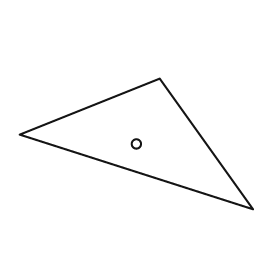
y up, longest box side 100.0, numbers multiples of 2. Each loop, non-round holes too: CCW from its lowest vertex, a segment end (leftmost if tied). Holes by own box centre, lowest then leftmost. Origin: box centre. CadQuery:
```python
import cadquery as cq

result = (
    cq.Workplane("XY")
    .moveTo(50.0, -28.0)
    .lineTo(10.0, 28.0)
    .lineTo(-50.0, 4.0)
    .close()
    .moveTo(0.0, 0.0)
    .circle(2.0)
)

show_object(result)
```